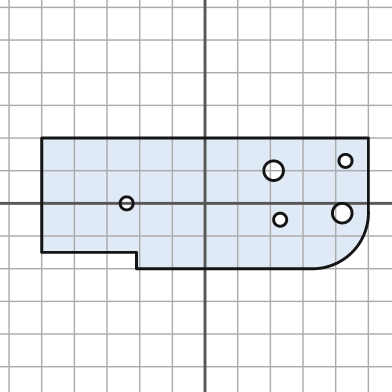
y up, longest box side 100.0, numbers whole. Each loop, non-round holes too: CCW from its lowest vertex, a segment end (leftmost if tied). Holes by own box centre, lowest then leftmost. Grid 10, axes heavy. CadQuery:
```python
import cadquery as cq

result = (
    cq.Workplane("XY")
    .moveTo(-21.0, -20.0)
    .lineTo(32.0, -20.0)
    .threePointArc((45.0, -15.0), (50.0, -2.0))
    .lineTo(50.0, 20.0)
    .lineTo(-50.0, 20.0)
    .lineTo(-50.0, -15.0)
    .lineTo(-21.0, -15.0)
    .close()
    .moveTo(23.0, -5.0)
    .circle(2.0)
    .moveTo(42.0, -3.0)
    .circle(3.0)
    .moveTo(-24.0, 0.0)
    .circle(2.0)
    .moveTo(21.0, 10.0)
    .circle(3.0)
    .moveTo(43.0, 13.0)
    .circle(2.0)
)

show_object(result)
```